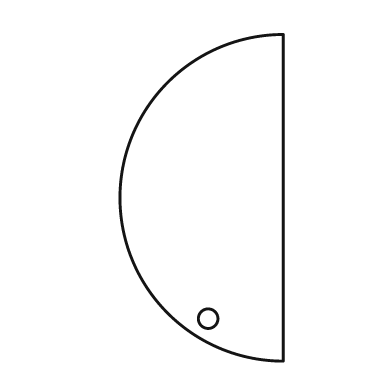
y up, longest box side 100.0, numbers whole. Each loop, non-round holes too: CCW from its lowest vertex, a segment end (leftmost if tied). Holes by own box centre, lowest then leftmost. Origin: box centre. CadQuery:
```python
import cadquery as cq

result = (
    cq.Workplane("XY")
    .moveTo(25.0, -50.0)
    .lineTo(25.0, 50.0)
    .threePointArc((-25.0, 0.0), (25.0, -50.0))
    .close()
    .moveTo(2.0, -37.0)
    .circle(3.0)
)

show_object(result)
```